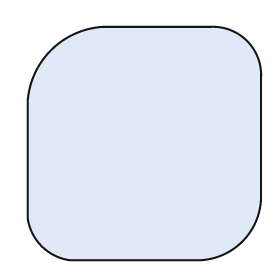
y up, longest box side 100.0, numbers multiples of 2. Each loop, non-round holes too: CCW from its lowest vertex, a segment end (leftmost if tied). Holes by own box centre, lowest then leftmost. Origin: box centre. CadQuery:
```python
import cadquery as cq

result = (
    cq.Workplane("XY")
    .moveTo(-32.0, -50.0)
    .lineTo(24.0, -50.0)
    .threePointArc((42.0, -42.0), (50.0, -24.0))
    .lineTo(50.0, 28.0)
    .threePointArc((44.0, 44.0), (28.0, 50.0))
    .lineTo(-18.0, 50.0)
    .threePointArc((-40.0, 40.0), (-50.0, 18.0))
    .lineTo(-50.0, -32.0)
    .threePointArc((-44.0, -44.0), (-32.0, -50.0))
    .close()
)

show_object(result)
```